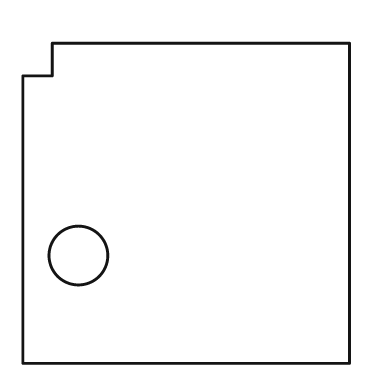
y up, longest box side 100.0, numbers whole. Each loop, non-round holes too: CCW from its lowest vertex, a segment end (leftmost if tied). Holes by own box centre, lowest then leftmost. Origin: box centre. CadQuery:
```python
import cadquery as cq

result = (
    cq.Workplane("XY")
    .moveTo(-50.0, -49.0)
    .lineTo(50.0, -49.0)
    .lineTo(50.0, 49.0)
    .lineTo(-41.0, 49.0)
    .lineTo(-41.0, 39.0)
    .lineTo(-50.0, 39.0)
    .close()
    .moveTo(-33.0, -16.0)
    .circle(9.0)
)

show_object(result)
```